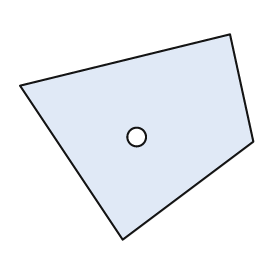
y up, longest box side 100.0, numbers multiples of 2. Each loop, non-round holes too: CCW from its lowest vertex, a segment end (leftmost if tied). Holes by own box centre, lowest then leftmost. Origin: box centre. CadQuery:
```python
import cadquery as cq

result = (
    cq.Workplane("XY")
    .moveTo(-6.0, -44.0)
    .lineTo(50.0, -2.0)
    .lineTo(40.0, 44.0)
    .lineTo(-50.0, 22.0)
    .close()
    .moveTo(0.0, 0.0)
    .circle(4.0)
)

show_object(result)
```